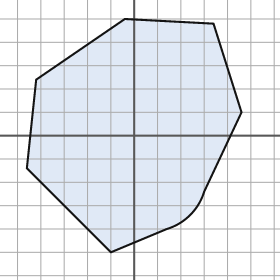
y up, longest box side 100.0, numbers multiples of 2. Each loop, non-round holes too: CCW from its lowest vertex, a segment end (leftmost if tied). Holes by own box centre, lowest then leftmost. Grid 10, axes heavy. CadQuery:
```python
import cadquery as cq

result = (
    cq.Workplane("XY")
    .moveTo(-10.0, -50.0)
    .lineTo(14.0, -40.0)
    .threePointArc((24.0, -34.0), (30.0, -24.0))
    .lineTo(46.0, 10.0)
    .lineTo(34.0, 48.0)
    .lineTo(-4.0, 50.0)
    .lineTo(-42.0, 24.0)
    .lineTo(-46.0, -14.0)
    .close()
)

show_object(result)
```